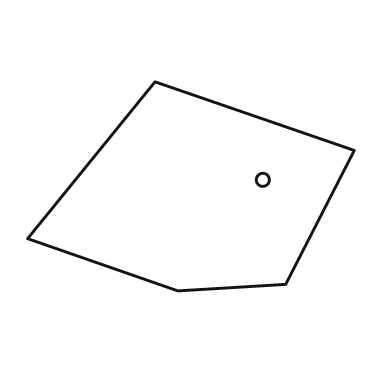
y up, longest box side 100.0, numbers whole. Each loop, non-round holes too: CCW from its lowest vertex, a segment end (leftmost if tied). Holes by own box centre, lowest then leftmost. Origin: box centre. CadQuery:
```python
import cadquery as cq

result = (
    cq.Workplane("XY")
    .moveTo(-4.0, -32.0)
    .lineTo(29.0, -30.0)
    .lineTo(50.0, 11.0)
    .lineTo(-11.0, 32.0)
    .lineTo(-50.0, -16.0)
    .close()
    .moveTo(22.0, 2.0)
    .circle(2.0)
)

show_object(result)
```